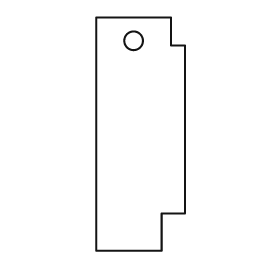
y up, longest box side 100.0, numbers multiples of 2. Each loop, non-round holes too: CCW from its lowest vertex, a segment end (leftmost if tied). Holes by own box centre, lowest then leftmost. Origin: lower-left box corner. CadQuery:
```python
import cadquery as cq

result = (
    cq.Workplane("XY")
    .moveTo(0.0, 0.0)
    .lineTo(28.0, 0.0)
    .lineTo(28.0, 16.0)
    .lineTo(38.0, 16.0)
    .lineTo(38.0, 88.0)
    .lineTo(32.0, 88.0)
    .lineTo(32.0, 100.0)
    .lineTo(0.0, 100.0)
    .close()
    .moveTo(16.0, 90.0)
    .circle(4.0)
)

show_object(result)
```